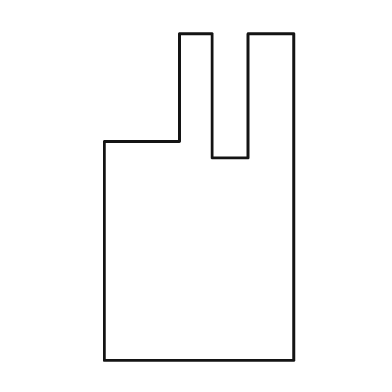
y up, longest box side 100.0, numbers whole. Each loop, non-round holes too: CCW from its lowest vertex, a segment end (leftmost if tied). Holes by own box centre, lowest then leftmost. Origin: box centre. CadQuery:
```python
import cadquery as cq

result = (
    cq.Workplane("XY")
    .moveTo(-29.0, -50.0)
    .lineTo(29.0, -50.0)
    .lineTo(29.0, 50.0)
    .lineTo(15.0, 50.0)
    .lineTo(15.0, 12.0)
    .lineTo(4.0, 12.0)
    .lineTo(4.0, 50.0)
    .lineTo(-6.0, 50.0)
    .lineTo(-6.0, 17.0)
    .lineTo(-29.0, 17.0)
    .close()
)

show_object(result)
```